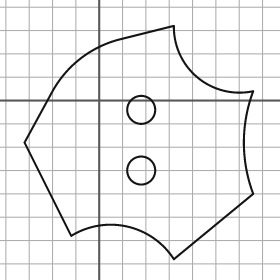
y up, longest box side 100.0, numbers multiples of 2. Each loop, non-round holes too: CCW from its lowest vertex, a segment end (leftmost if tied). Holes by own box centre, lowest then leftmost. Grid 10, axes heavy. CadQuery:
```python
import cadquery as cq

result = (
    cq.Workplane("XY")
    .moveTo(32.0, -68.0)
    .lineTo(66.0, -40.0)
    .threePointArc((62.0, -18.0), (66.0, 4.0))
    .threePointArc((42.0, 10.0), (32.0, 32.0))
    .lineTo(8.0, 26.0)
    .threePointArc((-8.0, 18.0), (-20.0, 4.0))
    .lineTo(-32.0, -18.0)
    .lineTo(-12.0, -58.0)
    .threePointArc((12.0, -54.0), (32.0, -68.0))
    .close()
    .moveTo(18.0, -30.0)
    .circle(6.0)
    .moveTo(18.0, -4.0)
    .circle(6.0)
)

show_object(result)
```